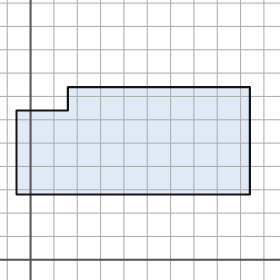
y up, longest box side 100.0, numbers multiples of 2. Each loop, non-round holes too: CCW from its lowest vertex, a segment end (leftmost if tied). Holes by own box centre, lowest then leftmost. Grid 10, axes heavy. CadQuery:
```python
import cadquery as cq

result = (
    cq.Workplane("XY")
    .moveTo(-6.0, 28.0)
    .lineTo(94.0, 28.0)
    .lineTo(94.0, 74.0)
    .lineTo(16.0, 74.0)
    .lineTo(16.0, 64.0)
    .lineTo(-6.0, 64.0)
    .close()
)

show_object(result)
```